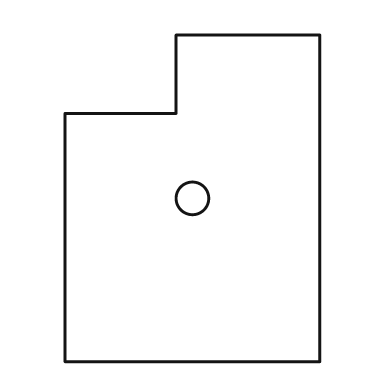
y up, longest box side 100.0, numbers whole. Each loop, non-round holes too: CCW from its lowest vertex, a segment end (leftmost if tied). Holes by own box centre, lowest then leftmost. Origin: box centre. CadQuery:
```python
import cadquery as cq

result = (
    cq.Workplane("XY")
    .moveTo(-39.0, -50.0)
    .lineTo(39.0, -50.0)
    .lineTo(39.0, 50.0)
    .lineTo(-5.0, 50.0)
    .lineTo(-5.0, 26.0)
    .lineTo(-39.0, 26.0)
    .close()
    .moveTo(0.0, 0.0)
    .circle(5.0)
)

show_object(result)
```